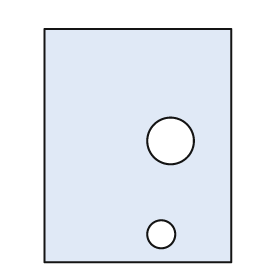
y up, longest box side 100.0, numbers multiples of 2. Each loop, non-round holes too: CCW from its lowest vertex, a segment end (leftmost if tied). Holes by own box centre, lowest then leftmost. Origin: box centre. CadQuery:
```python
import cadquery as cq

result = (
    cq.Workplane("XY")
    .moveTo(-40.0, -50.0)
    .lineTo(40.0, -50.0)
    .lineTo(40.0, 50.0)
    .lineTo(-40.0, 50.0)
    .close()
    .moveTo(10.0, -38.0)
    .circle(6.0)
    .moveTo(14.0, 2.0)
    .circle(10.0)
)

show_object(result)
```